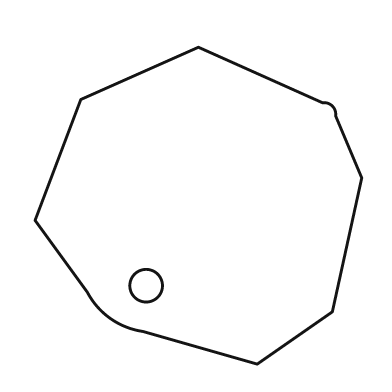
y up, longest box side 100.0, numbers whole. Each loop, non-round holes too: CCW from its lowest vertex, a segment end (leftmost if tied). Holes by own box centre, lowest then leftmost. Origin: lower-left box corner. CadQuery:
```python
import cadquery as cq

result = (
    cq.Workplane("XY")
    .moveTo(68.0, 0.0)
    .lineTo(91.0, 16.0)
    .lineTo(100.0, 57.0)
    .lineTo(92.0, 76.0)
    .threePointArc((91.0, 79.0), (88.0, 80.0))
    .lineTo(50.0, 97.0)
    .lineTo(14.0, 81.0)
    .lineTo(0.0, 44.0)
    .lineTo(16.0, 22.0)
    .threePointArc((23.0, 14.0), (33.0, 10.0))
    .close()
    .moveTo(34.0, 24.0)
    .circle(5.0)
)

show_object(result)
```